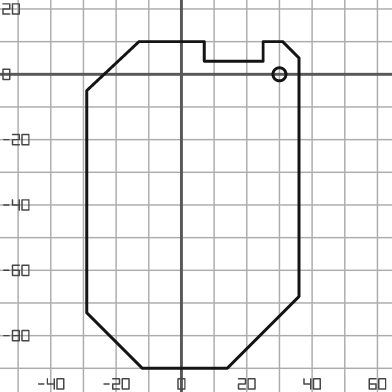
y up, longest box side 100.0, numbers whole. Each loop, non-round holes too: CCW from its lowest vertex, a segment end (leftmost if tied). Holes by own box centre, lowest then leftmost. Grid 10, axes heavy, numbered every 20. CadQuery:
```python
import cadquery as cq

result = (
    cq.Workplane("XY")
    .moveTo(-12.0, -90.0)
    .lineTo(14.0, -90.0)
    .lineTo(36.0, -68.0)
    .lineTo(36.0, 5.0)
    .lineTo(31.0, 10.0)
    .lineTo(25.0, 10.0)
    .lineTo(25.0, 4.0)
    .lineTo(7.0, 4.0)
    .lineTo(7.0, 10.0)
    .lineTo(-13.0, 10.0)
    .lineTo(-29.0, -5.0)
    .lineTo(-29.0, -73.0)
    .close()
    .moveTo(30.0, 0.0)
    .circle(2.0)
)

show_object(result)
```